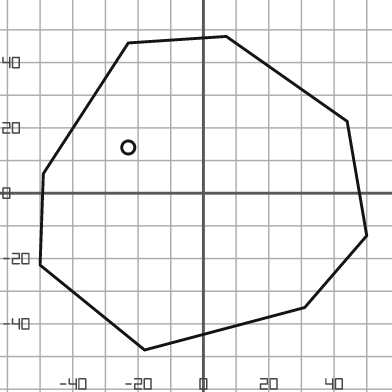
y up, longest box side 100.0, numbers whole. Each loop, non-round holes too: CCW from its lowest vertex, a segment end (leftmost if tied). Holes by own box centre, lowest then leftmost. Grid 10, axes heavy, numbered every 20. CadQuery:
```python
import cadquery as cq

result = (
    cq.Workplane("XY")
    .moveTo(-18.0, -48.0)
    .lineTo(31.0, -35.0)
    .lineTo(50.0, -13.0)
    .lineTo(44.0, 22.0)
    .lineTo(7.0, 48.0)
    .lineTo(-23.0, 46.0)
    .lineTo(-49.0, 6.0)
    .lineTo(-50.0, -22.0)
    .close()
    .moveTo(-23.0, 14.0)
    .circle(2.0)
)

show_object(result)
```